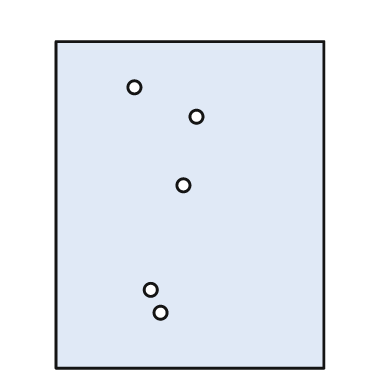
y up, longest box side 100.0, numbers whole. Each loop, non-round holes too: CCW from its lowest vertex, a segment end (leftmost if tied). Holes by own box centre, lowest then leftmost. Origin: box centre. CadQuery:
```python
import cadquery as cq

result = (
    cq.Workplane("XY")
    .moveTo(-41.0, -50.0)
    .lineTo(41.0, -50.0)
    .lineTo(41.0, 50.0)
    .lineTo(-41.0, 50.0)
    .close()
    .moveTo(-9.0, -33.0)
    .circle(2.0)
    .moveTo(-12.0, -26.0)
    .circle(2.0)
    .moveTo(-2.0, 6.0)
    .circle(2.0)
    .moveTo(2.0, 27.0)
    .circle(2.0)
    .moveTo(-17.0, 36.0)
    .circle(2.0)
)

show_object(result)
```